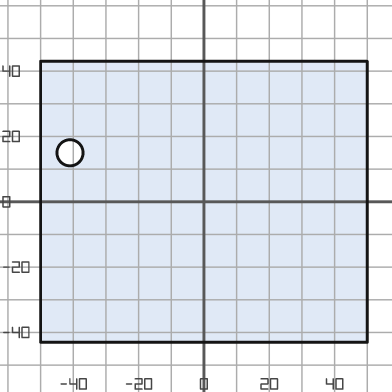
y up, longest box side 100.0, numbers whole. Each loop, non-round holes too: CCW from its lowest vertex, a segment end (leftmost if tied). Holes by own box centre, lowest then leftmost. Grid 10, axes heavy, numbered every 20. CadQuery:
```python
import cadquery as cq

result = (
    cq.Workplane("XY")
    .moveTo(-50.0, -43.0)
    .lineTo(50.0, -43.0)
    .lineTo(50.0, 43.0)
    .lineTo(-50.0, 43.0)
    .close()
    .moveTo(-41.0, 15.0)
    .circle(4.0)
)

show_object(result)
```